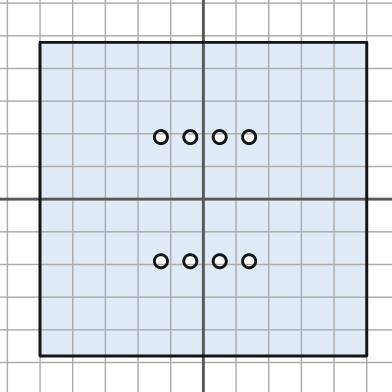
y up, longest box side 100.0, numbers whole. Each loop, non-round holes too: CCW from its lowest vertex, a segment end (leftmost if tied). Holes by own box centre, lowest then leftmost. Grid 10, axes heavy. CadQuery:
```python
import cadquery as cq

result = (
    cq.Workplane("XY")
    .moveTo(-50.0, -48.0)
    .lineTo(50.0, -48.0)
    .lineTo(50.0, 48.0)
    .lineTo(-50.0, 48.0)
    .close()
    .moveTo(-13.0, -19.0)
    .circle(2.0)
    .moveTo(-4.0, -19.0)
    .circle(2.0)
    .moveTo(5.0, -19.0)
    .circle(2.0)
    .moveTo(14.0, -19.0)
    .circle(2.0)
    .moveTo(-13.0, 19.0)
    .circle(2.0)
    .moveTo(-4.0, 19.0)
    .circle(2.0)
    .moveTo(5.0, 19.0)
    .circle(2.0)
    .moveTo(14.0, 19.0)
    .circle(2.0)
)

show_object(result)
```